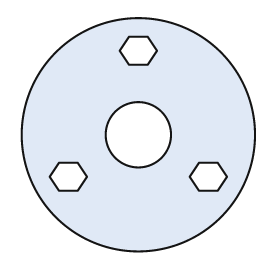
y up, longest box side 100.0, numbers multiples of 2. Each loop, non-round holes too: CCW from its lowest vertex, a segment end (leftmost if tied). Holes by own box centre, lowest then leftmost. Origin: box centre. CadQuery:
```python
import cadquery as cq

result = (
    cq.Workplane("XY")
    .moveTo(0.0, 0.0)
    .circle(50.0)
    .moveTo(-34.0, -24.0)
    .lineTo(-26.0, -24.0)
    .lineTo(-22.0, -18.0)
    .lineTo(-26.0, -12.0)
    .lineTo(-34.0, -12.0)
    .lineTo(-38.0, -18.0)
    .close()
    .moveTo(26.0, -24.0)
    .lineTo(34.0, -24.0)
    .lineTo(38.0, -18.0)
    .lineTo(34.0, -12.0)
    .lineTo(26.0, -12.0)
    .lineTo(22.0, -18.0)
    .close()
    .moveTo(0.0, 0.0)
    .circle(14.0)
    .moveTo(-4.0, 30.0)
    .lineTo(4.0, 30.0)
    .lineTo(8.0, 36.0)
    .lineTo(4.0, 42.0)
    .lineTo(-4.0, 42.0)
    .lineTo(-8.0, 36.0)
    .close()
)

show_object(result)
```